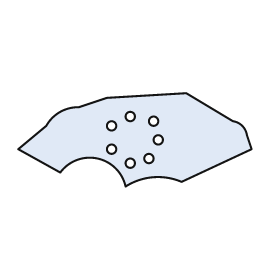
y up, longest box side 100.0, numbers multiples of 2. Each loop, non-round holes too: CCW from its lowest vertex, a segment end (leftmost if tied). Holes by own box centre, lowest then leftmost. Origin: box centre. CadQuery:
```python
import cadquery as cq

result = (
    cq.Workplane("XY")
    .moveTo(-4.0, -20.0)
    .threePointArc((8.0, -16.0), (20.0, -18.0))
    .lineTo(50.0, -4.0)
    .lineTo(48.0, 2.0)
    .threePointArc((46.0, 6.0), (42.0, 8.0))
    .lineTo(22.0, 20.0)
    .lineTo(-12.0, 18.0)
    .lineTo(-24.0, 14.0)
    .threePointArc((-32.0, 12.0), (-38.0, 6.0))
    .lineTo(-50.0, -4.0)
    .lineTo(-32.0, -14.0)
    .threePointArc((-16.0, -8.0), (-4.0, -20.0))
    .close()
    .moveTo(-2.0, -10.0)
    .circle(2.0)
    .moveTo(6.0, -8.0)
    .circle(2.0)
    .moveTo(-10.0, -4.0)
    .circle(2.0)
    .moveTo(10.0, 0.0)
    .circle(2.0)
    .moveTo(-10.0, 6.0)
    .circle(2.0)
    .moveTo(8.0, 8.0)
    .circle(2.0)
    .moveTo(-2.0, 10.0)
    .circle(2.0)
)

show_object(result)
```